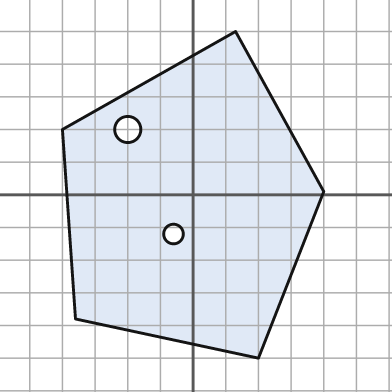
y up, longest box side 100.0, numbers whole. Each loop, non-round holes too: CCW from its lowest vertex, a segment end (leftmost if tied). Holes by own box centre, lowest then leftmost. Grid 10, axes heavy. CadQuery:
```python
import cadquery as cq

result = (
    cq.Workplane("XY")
    .moveTo(20.0, -50.0)
    .lineTo(40.0, 1.0)
    .lineTo(13.0, 50.0)
    .lineTo(-40.0, 20.0)
    .lineTo(-36.0, -38.0)
    .close()
    .moveTo(-6.0, -12.0)
    .circle(3.0)
    .moveTo(-20.0, 20.0)
    .circle(4.0)
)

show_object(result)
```